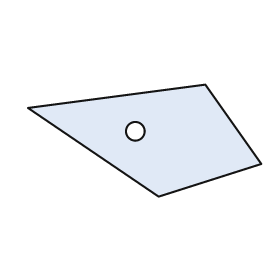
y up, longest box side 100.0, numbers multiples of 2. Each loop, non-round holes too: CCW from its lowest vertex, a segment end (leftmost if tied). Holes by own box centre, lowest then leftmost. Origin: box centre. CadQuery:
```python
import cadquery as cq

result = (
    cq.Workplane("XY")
    .moveTo(6.0, -24.0)
    .lineTo(50.0, -10.0)
    .lineTo(26.0, 24.0)
    .lineTo(-50.0, 14.0)
    .close()
    .moveTo(-4.0, 4.0)
    .circle(4.0)
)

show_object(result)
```